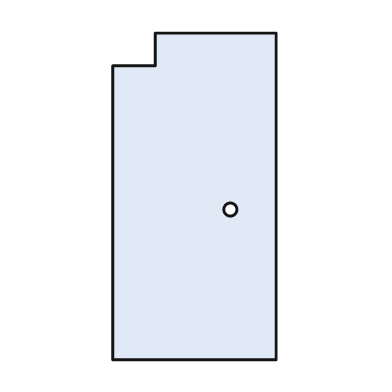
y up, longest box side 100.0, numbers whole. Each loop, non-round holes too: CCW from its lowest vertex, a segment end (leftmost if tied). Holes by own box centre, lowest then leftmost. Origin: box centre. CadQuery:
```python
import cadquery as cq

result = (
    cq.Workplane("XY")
    .moveTo(-25.0, -50.0)
    .lineTo(25.0, -50.0)
    .lineTo(25.0, 50.0)
    .lineTo(-12.0, 50.0)
    .lineTo(-12.0, 40.0)
    .lineTo(-25.0, 40.0)
    .close()
    .moveTo(11.0, -4.0)
    .circle(2.0)
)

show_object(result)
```